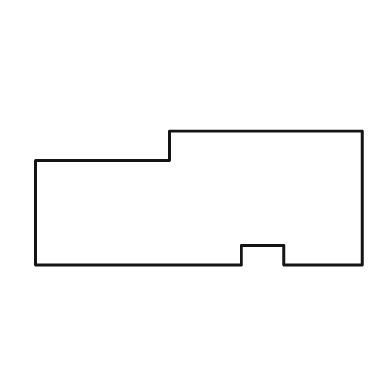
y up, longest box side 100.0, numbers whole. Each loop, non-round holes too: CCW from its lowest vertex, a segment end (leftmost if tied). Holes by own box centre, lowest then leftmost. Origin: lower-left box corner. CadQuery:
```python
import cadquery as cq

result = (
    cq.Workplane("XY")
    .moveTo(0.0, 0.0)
    .lineTo(63.0, 0.0)
    .lineTo(63.0, 6.0)
    .lineTo(76.0, 6.0)
    .lineTo(76.0, 0.0)
    .lineTo(100.0, 0.0)
    .lineTo(100.0, 41.0)
    .lineTo(41.0, 41.0)
    .lineTo(41.0, 32.0)
    .lineTo(0.0, 32.0)
    .close()
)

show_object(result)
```